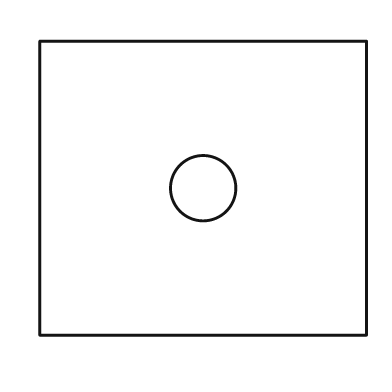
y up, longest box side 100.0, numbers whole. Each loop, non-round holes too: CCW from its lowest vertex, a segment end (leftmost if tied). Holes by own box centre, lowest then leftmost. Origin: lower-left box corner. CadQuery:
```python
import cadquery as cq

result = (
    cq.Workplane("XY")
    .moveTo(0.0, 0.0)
    .lineTo(100.0, 0.0)
    .lineTo(100.0, 90.0)
    .lineTo(0.0, 90.0)
    .close()
    .moveTo(50.0, 45.0)
    .circle(10.0)
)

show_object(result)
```